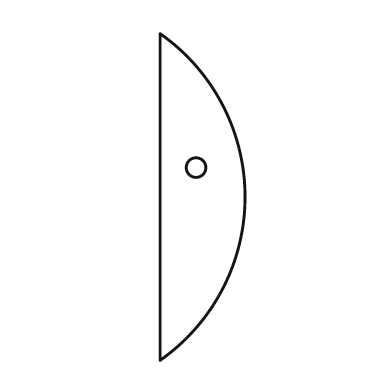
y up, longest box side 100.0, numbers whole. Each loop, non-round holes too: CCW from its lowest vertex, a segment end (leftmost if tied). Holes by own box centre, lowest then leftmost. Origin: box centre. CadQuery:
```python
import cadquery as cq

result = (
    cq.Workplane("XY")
    .moveTo(-13.0, -50.0)
    .threePointArc((13.0, 0.0), (-13.0, 50.0))
    .close()
    .moveTo(-2.0, 9.0)
    .circle(3.0)
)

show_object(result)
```